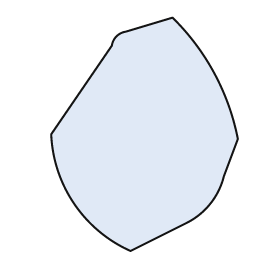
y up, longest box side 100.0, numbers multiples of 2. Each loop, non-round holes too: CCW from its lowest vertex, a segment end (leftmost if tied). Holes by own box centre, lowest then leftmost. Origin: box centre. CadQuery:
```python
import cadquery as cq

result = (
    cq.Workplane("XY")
    .moveTo(-6.0, -50.0)
    .lineTo(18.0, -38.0)
    .threePointArc((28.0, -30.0), (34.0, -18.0))
    .lineTo(40.0, -2.0)
    .threePointArc((30.0, 26.0), (12.0, 50.0))
    .lineTo(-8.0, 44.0)
    .threePointArc((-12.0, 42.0), (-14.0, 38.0))
    .lineTo(-40.0, 0.0)
    .threePointArc((-30.0, -30.0), (-6.0, -50.0))
    .close()
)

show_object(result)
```